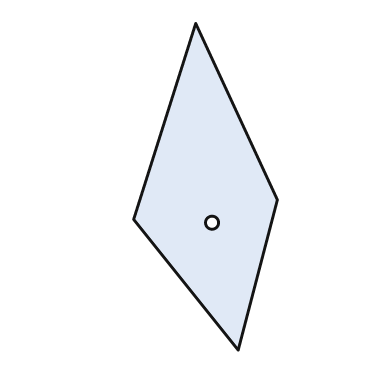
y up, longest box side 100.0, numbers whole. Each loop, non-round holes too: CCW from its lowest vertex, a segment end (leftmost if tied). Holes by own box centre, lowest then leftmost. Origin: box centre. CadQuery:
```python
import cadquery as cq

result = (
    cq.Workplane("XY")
    .moveTo(10.0, -50.0)
    .lineTo(22.0, -4.0)
    .lineTo(-3.0, 50.0)
    .lineTo(-22.0, -10.0)
    .close()
    .moveTo(2.0, -11.0)
    .circle(2.0)
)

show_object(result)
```